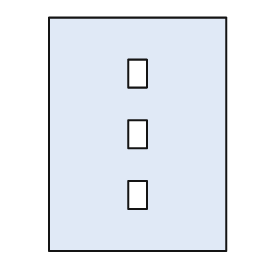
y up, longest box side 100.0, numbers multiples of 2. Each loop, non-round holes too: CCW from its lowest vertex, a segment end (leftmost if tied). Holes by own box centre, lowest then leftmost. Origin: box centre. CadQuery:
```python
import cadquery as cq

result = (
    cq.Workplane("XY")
    .moveTo(-38.0, -50.0)
    .lineTo(38.0, -50.0)
    .lineTo(38.0, 50.0)
    .lineTo(-38.0, 50.0)
    .close()
    .moveTo(-4.0, -32.0)
    .lineTo(4.0, -32.0)
    .lineTo(4.0, -20.0)
    .lineTo(-4.0, -20.0)
    .close()
    .moveTo(-4.0, -6.0)
    .lineTo(4.0, -6.0)
    .lineTo(4.0, 6.0)
    .lineTo(-4.0, 6.0)
    .close()
    .moveTo(-4.0, 20.0)
    .lineTo(4.0, 20.0)
    .lineTo(4.0, 32.0)
    .lineTo(-4.0, 32.0)
    .close()
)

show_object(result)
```